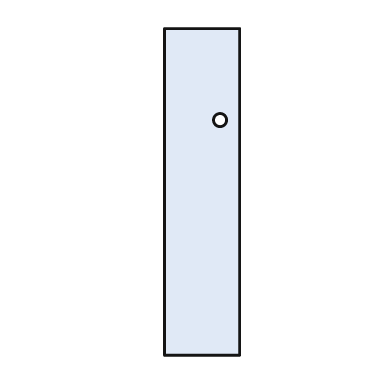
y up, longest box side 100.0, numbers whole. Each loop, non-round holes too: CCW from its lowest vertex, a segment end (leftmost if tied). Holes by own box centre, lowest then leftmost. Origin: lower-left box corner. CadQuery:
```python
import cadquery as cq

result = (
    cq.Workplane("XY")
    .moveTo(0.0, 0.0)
    .lineTo(23.0, 0.0)
    .lineTo(23.0, 100.0)
    .lineTo(0.0, 100.0)
    .close()
    .moveTo(17.0, 72.0)
    .circle(2.0)
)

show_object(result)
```